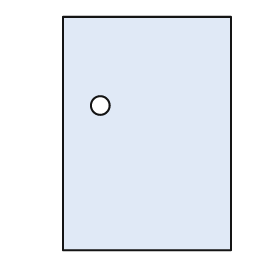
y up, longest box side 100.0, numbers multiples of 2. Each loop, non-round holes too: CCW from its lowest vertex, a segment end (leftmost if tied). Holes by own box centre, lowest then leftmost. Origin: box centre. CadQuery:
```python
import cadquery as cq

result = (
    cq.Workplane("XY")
    .moveTo(-36.0, -50.0)
    .lineTo(36.0, -50.0)
    .lineTo(36.0, 50.0)
    .lineTo(-36.0, 50.0)
    .close()
    .moveTo(-20.0, 12.0)
    .circle(4.0)
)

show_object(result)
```